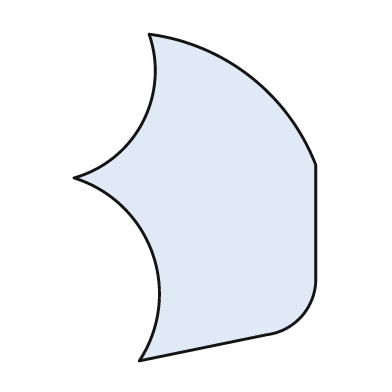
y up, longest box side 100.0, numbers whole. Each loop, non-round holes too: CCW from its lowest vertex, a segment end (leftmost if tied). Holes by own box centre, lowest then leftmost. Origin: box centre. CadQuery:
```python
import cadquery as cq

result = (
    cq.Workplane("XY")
    .moveTo(-17.0, -50.0)
    .lineTo(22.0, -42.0)
    .threePointArc((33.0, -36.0), (37.0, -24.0))
    .lineTo(37.0, 10.0)
    .threePointArc((17.0, 37.0), (-14.0, 50.0))
    .threePointArc((-16.0, 23.0), (-37.0, 6.0))
    .threePointArc((-13.0, -17.0), (-17.0, -50.0))
    .close()
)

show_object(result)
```